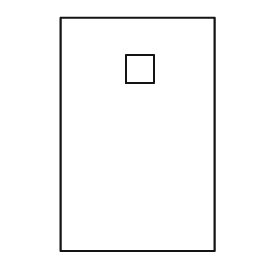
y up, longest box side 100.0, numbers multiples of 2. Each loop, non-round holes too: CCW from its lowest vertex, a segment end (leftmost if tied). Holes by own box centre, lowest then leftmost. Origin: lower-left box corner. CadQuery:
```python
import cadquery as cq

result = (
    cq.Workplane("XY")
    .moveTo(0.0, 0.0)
    .lineTo(66.0, 0.0)
    .lineTo(66.0, 100.0)
    .lineTo(0.0, 100.0)
    .close()
    .moveTo(28.0, 72.0)
    .lineTo(40.0, 72.0)
    .lineTo(40.0, 84.0)
    .lineTo(28.0, 84.0)
    .close()
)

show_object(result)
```